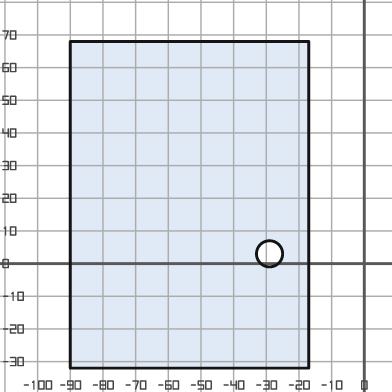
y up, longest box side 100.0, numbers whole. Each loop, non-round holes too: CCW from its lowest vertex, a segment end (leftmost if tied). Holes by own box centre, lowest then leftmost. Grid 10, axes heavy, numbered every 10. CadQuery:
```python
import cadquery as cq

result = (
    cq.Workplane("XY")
    .moveTo(-90.0, -32.0)
    .lineTo(-17.0, -32.0)
    .lineTo(-17.0, 68.0)
    .lineTo(-90.0, 68.0)
    .close()
    .moveTo(-29.0, 3.0)
    .circle(4.0)
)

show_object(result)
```